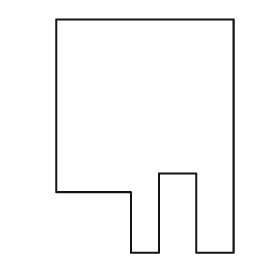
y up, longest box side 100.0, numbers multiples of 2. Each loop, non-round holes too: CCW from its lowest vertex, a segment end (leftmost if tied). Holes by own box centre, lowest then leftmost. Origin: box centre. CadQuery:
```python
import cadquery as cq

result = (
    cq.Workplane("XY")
    .moveTo(-6.0, -50.0)
    .lineTo(6.0, -50.0)
    .lineTo(6.0, -16.0)
    .lineTo(22.0, -16.0)
    .lineTo(22.0, -50.0)
    .lineTo(38.0, -50.0)
    .lineTo(38.0, 50.0)
    .lineTo(-38.0, 50.0)
    .lineTo(-38.0, -24.0)
    .lineTo(-6.0, -24.0)
    .close()
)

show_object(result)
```